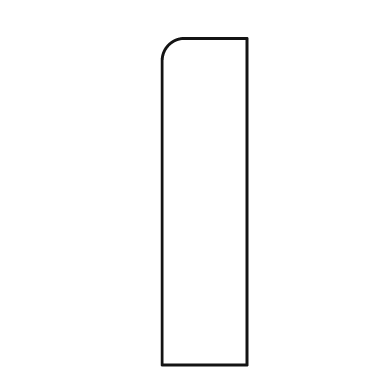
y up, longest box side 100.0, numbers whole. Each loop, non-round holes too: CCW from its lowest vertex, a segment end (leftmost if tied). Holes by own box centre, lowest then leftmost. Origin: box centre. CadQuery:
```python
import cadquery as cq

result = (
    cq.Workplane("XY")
    .moveTo(-13.0, -50.0)
    .lineTo(13.0, -50.0)
    .lineTo(13.0, 50.0)
    .lineTo(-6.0, 50.0)
    .threePointArc((-11.0, 48.0), (-13.0, 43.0))
    .close()
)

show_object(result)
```